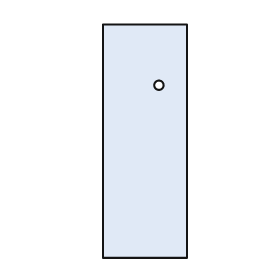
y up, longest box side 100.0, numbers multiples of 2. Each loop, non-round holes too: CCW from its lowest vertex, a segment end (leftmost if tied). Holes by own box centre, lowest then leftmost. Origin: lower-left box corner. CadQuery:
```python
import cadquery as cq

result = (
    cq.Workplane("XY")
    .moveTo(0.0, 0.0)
    .lineTo(36.0, 0.0)
    .lineTo(36.0, 100.0)
    .lineTo(0.0, 100.0)
    .close()
    .moveTo(24.0, 74.0)
    .circle(2.0)
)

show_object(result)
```